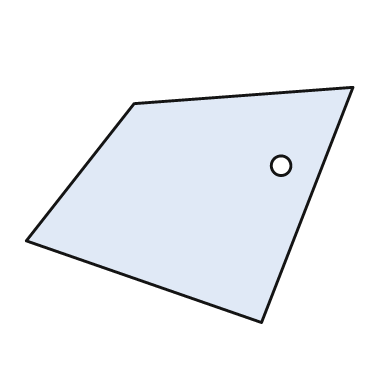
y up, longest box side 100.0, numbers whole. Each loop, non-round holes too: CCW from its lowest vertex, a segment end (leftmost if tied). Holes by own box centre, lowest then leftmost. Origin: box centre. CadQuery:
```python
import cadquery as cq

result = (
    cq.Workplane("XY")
    .moveTo(22.0, -36.0)
    .lineTo(50.0, 36.0)
    .lineTo(-17.0, 31.0)
    .lineTo(-50.0, -11.0)
    .close()
    .moveTo(28.0, 12.0)
    .circle(3.0)
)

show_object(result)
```